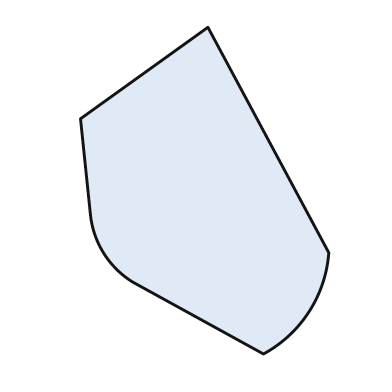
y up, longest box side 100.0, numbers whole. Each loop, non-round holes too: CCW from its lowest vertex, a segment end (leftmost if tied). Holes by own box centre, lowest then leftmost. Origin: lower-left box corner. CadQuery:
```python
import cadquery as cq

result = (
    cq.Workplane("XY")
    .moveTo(56.0, 0.0)
    .threePointArc((70.0, 13.0), (76.0, 31.0))
    .lineTo(39.0, 100.0)
    .lineTo(0.0, 72.0)
    .lineTo(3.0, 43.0)
    .threePointArc((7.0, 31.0), (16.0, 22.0))
    .close()
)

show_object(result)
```